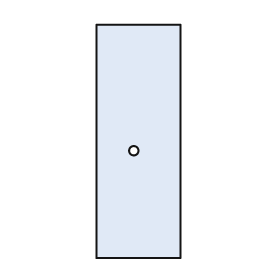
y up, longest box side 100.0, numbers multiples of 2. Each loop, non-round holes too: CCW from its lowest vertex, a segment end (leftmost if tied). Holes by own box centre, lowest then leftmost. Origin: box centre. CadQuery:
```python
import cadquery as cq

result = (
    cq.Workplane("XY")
    .moveTo(-18.0, -50.0)
    .lineTo(18.0, -50.0)
    .lineTo(18.0, 50.0)
    .lineTo(-18.0, 50.0)
    .close()
    .moveTo(-2.0, -4.0)
    .circle(2.0)
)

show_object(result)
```